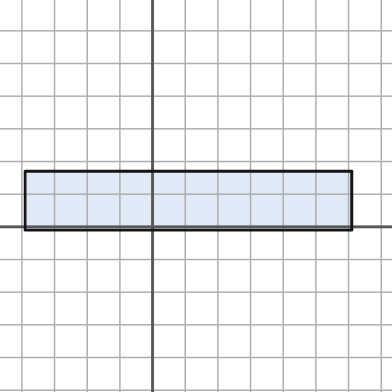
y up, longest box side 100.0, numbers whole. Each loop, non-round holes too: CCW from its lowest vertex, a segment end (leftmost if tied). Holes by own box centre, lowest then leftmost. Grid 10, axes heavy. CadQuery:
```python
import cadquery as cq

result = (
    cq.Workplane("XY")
    .moveTo(-39.0, -1.0)
    .lineTo(61.0, -1.0)
    .lineTo(61.0, 17.0)
    .lineTo(-39.0, 17.0)
    .close()
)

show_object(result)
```